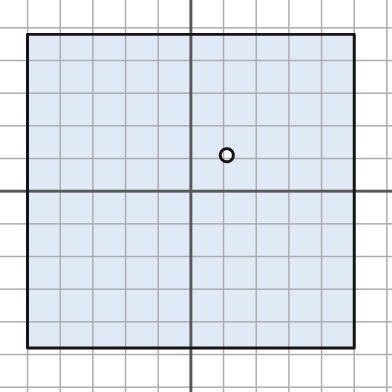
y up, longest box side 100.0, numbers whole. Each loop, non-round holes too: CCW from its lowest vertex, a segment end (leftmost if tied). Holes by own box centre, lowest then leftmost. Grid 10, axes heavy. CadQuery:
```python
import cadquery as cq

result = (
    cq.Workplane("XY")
    .moveTo(-50.0, -48.0)
    .lineTo(50.0, -48.0)
    .lineTo(50.0, 48.0)
    .lineTo(-50.0, 48.0)
    .close()
    .moveTo(11.0, 11.0)
    .circle(2.0)
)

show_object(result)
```